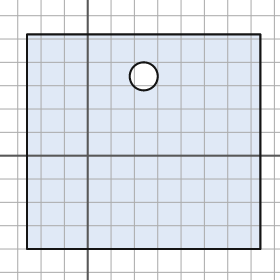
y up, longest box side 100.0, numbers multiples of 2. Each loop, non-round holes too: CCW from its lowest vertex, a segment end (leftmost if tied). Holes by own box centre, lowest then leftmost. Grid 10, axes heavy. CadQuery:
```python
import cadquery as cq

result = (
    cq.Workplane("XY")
    .moveTo(-26.0, -40.0)
    .lineTo(74.0, -40.0)
    .lineTo(74.0, 52.0)
    .lineTo(-26.0, 52.0)
    .close()
    .moveTo(24.0, 34.0)
    .circle(6.0)
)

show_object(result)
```